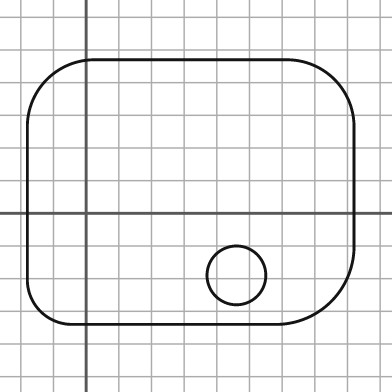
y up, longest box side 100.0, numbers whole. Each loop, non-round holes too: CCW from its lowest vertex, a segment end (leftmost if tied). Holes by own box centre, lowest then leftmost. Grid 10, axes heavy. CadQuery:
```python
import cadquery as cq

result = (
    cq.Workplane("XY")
    .moveTo(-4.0, -34.0)
    .lineTo(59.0, -34.0)
    .threePointArc((75.0, -27.0), (82.0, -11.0))
    .lineTo(82.0, 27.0)
    .threePointArc((76.0, 41.0), (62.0, 47.0))
    .lineTo(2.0, 47.0)
    .threePointArc((-12.0, 41.0), (-18.0, 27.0))
    .lineTo(-18.0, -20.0)
    .threePointArc((-14.0, -30.0), (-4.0, -34.0))
    .close()
    .moveTo(46.0, -19.0)
    .circle(9.0)
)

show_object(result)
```